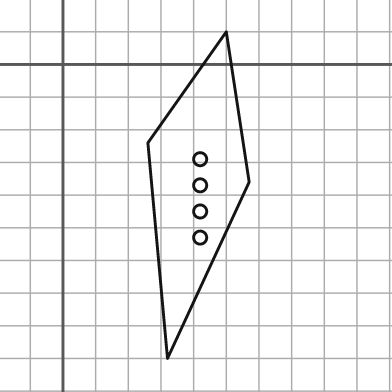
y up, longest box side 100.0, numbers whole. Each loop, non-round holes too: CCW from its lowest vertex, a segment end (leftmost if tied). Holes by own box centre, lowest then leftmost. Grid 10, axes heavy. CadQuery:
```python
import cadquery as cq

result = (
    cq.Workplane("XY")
    .moveTo(32.0, -90.0)
    .lineTo(57.0, -36.0)
    .lineTo(50.0, 10.0)
    .lineTo(26.0, -24.0)
    .close()
    .moveTo(42.0, -53.0)
    .circle(2.0)
    .moveTo(42.0, -45.0)
    .circle(2.0)
    .moveTo(42.0, -37.0)
    .circle(2.0)
    .moveTo(42.0, -29.0)
    .circle(2.0)
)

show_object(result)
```